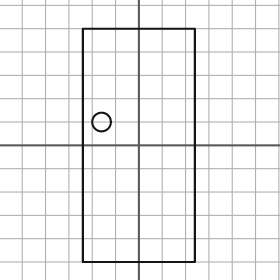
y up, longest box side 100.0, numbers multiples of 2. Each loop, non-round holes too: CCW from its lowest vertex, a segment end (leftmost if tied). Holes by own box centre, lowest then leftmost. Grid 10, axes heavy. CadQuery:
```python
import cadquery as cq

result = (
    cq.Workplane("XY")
    .moveTo(-24.0, -50.0)
    .lineTo(24.0, -50.0)
    .lineTo(24.0, 50.0)
    .lineTo(-24.0, 50.0)
    .close()
    .moveTo(-16.0, 10.0)
    .circle(4.0)
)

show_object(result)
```